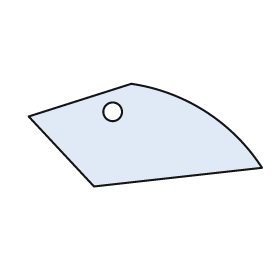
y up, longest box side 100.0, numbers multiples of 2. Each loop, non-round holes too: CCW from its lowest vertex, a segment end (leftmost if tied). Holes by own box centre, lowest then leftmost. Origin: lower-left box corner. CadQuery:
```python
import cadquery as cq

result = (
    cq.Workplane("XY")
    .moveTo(28.0, 0.0)
    .lineTo(100.0, 8.0)
    .threePointArc((76.0, 32.0), (44.0, 44.0))
    .lineTo(0.0, 30.0)
    .close()
    .moveTo(36.0, 32.0)
    .circle(4.0)
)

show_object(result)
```